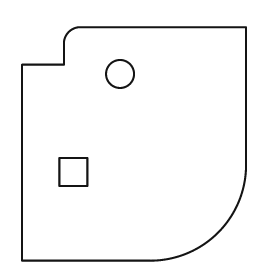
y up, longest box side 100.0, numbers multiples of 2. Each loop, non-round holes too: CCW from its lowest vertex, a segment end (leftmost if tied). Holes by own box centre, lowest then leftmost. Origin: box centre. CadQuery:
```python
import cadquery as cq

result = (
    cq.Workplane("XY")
    .moveTo(-48.0, -50.0)
    .lineTo(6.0, -50.0)
    .threePointArc((36.0, -38.0), (48.0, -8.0))
    .lineTo(48.0, 50.0)
    .lineTo(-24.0, 50.0)
    .threePointArc((-28.0, 48.0), (-30.0, 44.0))
    .lineTo(-30.0, 34.0)
    .lineTo(-48.0, 34.0)
    .close()
    .moveTo(-32.0, -18.0)
    .lineTo(-20.0, -18.0)
    .lineTo(-20.0, -6.0)
    .lineTo(-32.0, -6.0)
    .close()
    .moveTo(-6.0, 30.0)
    .circle(6.0)
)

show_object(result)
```